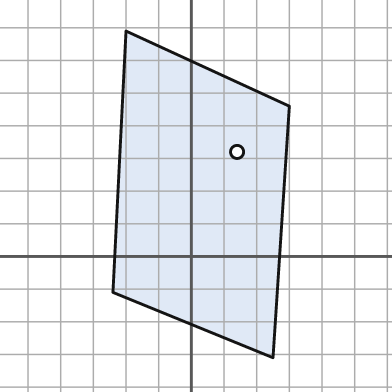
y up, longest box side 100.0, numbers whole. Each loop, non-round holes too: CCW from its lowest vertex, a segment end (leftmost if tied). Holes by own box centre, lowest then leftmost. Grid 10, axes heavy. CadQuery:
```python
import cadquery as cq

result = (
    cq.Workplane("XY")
    .moveTo(25.0, -31.0)
    .lineTo(30.0, 46.0)
    .lineTo(-20.0, 69.0)
    .lineTo(-24.0, -11.0)
    .close()
    .moveTo(14.0, 32.0)
    .circle(2.0)
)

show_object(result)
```